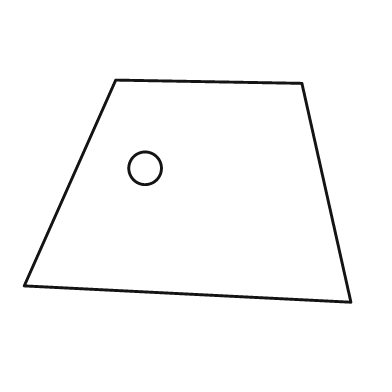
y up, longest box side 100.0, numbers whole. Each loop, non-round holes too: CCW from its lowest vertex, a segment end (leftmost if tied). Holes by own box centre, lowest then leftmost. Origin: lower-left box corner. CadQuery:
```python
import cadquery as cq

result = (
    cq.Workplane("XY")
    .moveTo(100.0, 0.0)
    .lineTo(85.0, 67.0)
    .lineTo(28.0, 68.0)
    .lineTo(0.0, 5.0)
    .close()
    .moveTo(37.0, 41.0)
    .circle(5.0)
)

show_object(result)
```